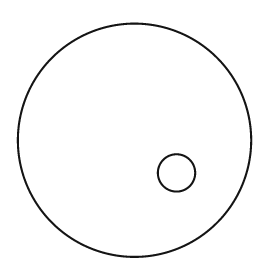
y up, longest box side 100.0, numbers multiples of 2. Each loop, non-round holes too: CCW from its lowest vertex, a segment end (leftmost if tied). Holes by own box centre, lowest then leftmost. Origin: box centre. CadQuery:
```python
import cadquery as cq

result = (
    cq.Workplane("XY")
    .moveTo(0.0, 0.0)
    .circle(50.0)
    .moveTo(18.0, -14.0)
    .circle(8.0)
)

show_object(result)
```